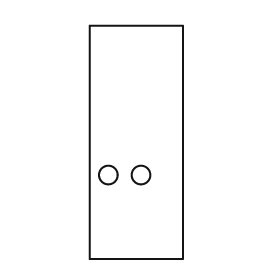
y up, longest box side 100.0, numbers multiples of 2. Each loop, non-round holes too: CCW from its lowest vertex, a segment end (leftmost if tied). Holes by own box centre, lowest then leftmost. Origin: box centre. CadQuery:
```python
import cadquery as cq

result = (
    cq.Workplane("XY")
    .moveTo(-20.0, -50.0)
    .lineTo(20.0, -50.0)
    .lineTo(20.0, 50.0)
    .lineTo(-20.0, 50.0)
    .close()
    .moveTo(-12.0, -14.0)
    .circle(4.0)
    .moveTo(2.0, -14.0)
    .circle(4.0)
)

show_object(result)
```